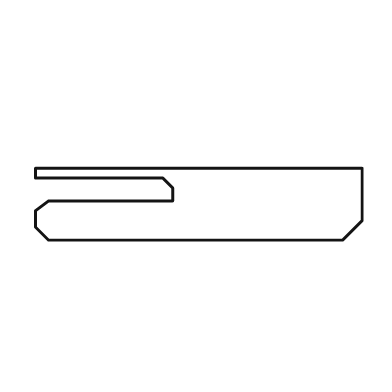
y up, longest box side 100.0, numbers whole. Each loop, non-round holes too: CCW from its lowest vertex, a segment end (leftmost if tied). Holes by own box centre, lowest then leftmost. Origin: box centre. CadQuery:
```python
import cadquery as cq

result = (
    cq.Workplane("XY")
    .moveTo(-46.0, -11.0)
    .lineTo(44.0, -11.0)
    .lineTo(50.0, -5.0)
    .lineTo(50.0, 11.0)
    .lineTo(-50.0, 11.0)
    .lineTo(-50.0, 8.0)
    .lineTo(-11.0, 8.0)
    .lineTo(-8.0, 5.0)
    .lineTo(-8.0, 1.0)
    .lineTo(-46.0, 1.0)
    .lineTo(-50.0, -2.0)
    .lineTo(-50.0, -7.0)
    .close()
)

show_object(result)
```